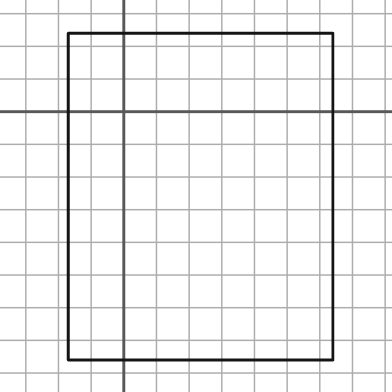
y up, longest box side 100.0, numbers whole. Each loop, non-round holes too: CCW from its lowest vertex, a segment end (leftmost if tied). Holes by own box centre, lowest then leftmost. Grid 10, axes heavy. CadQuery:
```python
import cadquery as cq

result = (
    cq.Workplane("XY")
    .moveTo(-17.0, -76.0)
    .lineTo(64.0, -76.0)
    .lineTo(64.0, 24.0)
    .lineTo(-17.0, 24.0)
    .close()
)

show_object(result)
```